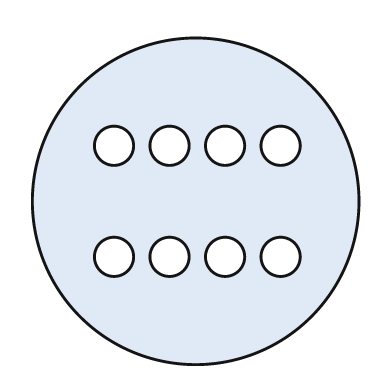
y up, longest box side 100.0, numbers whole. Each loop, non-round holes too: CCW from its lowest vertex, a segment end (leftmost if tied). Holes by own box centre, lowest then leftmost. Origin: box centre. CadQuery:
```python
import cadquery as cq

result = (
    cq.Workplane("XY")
    .moveTo(0.0, 0.0)
    .circle(50.0)
    .moveTo(-25.0, -17.0)
    .circle(6.0)
    .moveTo(-8.0, -17.0)
    .circle(6.0)
    .moveTo(9.0, -17.0)
    .circle(6.0)
    .moveTo(26.0, -17.0)
    .circle(6.0)
    .moveTo(-25.0, 17.0)
    .circle(6.0)
    .moveTo(-8.0, 17.0)
    .circle(6.0)
    .moveTo(9.0, 17.0)
    .circle(6.0)
    .moveTo(26.0, 17.0)
    .circle(6.0)
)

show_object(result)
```